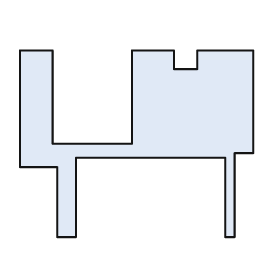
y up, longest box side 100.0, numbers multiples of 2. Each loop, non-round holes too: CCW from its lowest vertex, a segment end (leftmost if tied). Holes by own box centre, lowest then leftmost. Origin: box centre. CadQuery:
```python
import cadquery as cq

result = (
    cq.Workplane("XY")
    .moveTo(-34.0, -40.0)
    .lineTo(-26.0, -40.0)
    .lineTo(-26.0, -6.0)
    .lineTo(38.0, -6.0)
    .lineTo(38.0, -40.0)
    .lineTo(42.0, -40.0)
    .lineTo(42.0, -4.0)
    .lineTo(50.0, -4.0)
    .lineTo(50.0, 40.0)
    .lineTo(26.0, 40.0)
    .lineTo(26.0, 32.0)
    .lineTo(16.0, 32.0)
    .lineTo(16.0, 40.0)
    .lineTo(-2.0, 40.0)
    .lineTo(-2.0, 0.0)
    .lineTo(-36.0, 0.0)
    .lineTo(-36.0, 40.0)
    .lineTo(-50.0, 40.0)
    .lineTo(-50.0, -10.0)
    .lineTo(-34.0, -10.0)
    .close()
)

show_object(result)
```